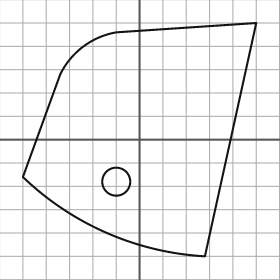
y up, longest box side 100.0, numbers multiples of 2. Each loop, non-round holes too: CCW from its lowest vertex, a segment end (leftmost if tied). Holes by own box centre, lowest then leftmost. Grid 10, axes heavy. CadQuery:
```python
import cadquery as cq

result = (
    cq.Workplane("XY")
    .moveTo(28.0, -50.0)
    .lineTo(50.0, 50.0)
    .lineTo(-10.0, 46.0)
    .threePointArc((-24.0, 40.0), (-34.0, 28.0))
    .lineTo(-50.0, -16.0)
    .threePointArc((-14.0, -40.0), (28.0, -50.0))
    .close()
    .moveTo(-10.0, -18.0)
    .circle(6.0)
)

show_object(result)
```